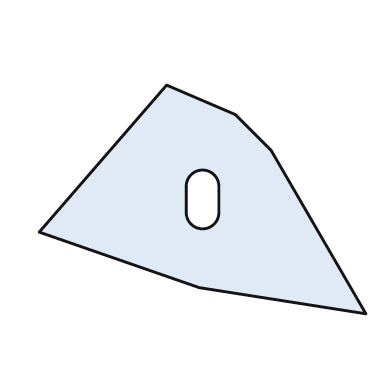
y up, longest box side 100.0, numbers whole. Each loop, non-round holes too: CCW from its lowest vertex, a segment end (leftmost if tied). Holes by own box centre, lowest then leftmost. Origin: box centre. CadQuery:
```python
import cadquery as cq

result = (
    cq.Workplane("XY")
    .moveTo(50.0, -35.0)
    .lineTo(21.0, 15.0)
    .lineTo(10.0, 26.0)
    .lineTo(-11.0, 35.0)
    .lineTo(-50.0, -10.0)
    .lineTo(-1.0, -27.0)
    .close()
    .moveTo(-5.0, -4.0)
    .threePointArc((0.0, -9.0), (5.0, -4.0))
    .lineTo(5.0, 4.0)
    .threePointArc((0.0, 9.0), (-5.0, 4.0))
    .close()
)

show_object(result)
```